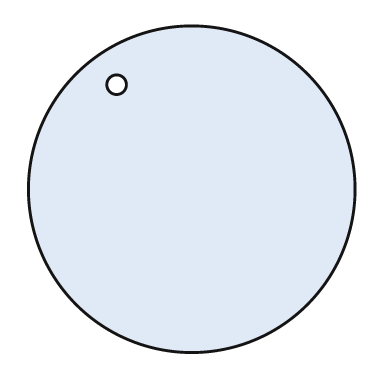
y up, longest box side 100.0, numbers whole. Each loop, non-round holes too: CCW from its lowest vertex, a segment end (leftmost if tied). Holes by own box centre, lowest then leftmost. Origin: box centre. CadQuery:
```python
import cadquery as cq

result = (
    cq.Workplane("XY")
    .moveTo(0.0, 0.0)
    .circle(50.0)
    .moveTo(-23.0, 32.0)
    .circle(3.0)
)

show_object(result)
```